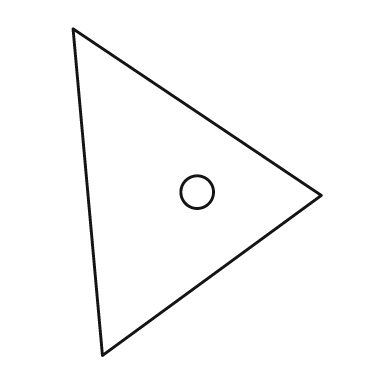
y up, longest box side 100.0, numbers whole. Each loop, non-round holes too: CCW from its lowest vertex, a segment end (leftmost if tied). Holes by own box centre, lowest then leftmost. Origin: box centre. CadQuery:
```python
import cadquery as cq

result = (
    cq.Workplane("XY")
    .moveTo(-29.0, -50.0)
    .lineTo(38.0, -1.0)
    .lineTo(-38.0, 50.0)
    .close()
    .moveTo(0.0, 0.0)
    .circle(5.0)
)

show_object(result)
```